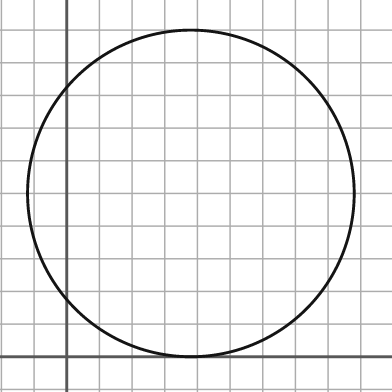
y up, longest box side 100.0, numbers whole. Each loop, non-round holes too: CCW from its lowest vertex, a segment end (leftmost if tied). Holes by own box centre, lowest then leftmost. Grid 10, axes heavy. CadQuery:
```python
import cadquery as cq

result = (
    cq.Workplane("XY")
    .moveTo(38.0, 50.0)
    .circle(50.0)
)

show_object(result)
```